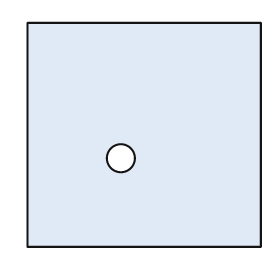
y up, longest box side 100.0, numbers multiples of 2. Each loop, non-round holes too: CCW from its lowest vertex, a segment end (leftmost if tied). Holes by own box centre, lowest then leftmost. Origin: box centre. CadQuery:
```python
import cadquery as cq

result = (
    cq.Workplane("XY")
    .moveTo(-50.0, -48.0)
    .lineTo(50.0, -48.0)
    .lineTo(50.0, 48.0)
    .lineTo(-50.0, 48.0)
    .close()
    .moveTo(-10.0, -10.0)
    .circle(6.0)
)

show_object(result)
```